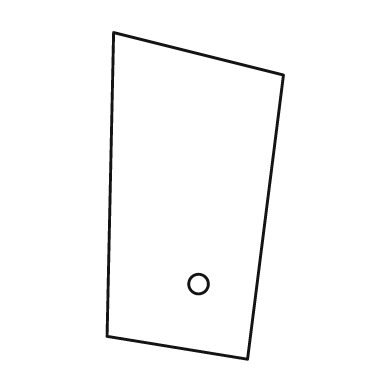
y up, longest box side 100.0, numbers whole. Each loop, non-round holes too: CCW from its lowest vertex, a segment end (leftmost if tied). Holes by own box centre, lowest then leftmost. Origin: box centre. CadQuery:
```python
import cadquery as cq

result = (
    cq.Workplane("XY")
    .moveTo(16.0, -50.0)
    .lineTo(27.0, 37.0)
    .lineTo(-25.0, 50.0)
    .lineTo(-27.0, -43.0)
    .close()
    .moveTo(1.0, -27.0)
    .circle(3.0)
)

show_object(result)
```